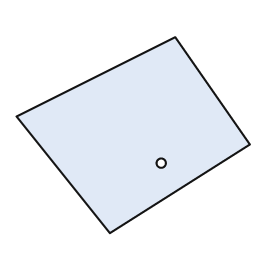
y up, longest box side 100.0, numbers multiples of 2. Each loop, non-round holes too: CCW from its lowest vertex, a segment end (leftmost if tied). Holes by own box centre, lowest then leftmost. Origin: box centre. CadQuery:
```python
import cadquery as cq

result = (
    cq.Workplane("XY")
    .moveTo(-10.0, -42.0)
    .lineTo(50.0, -4.0)
    .lineTo(18.0, 42.0)
    .lineTo(-50.0, 8.0)
    .close()
    .moveTo(12.0, -12.0)
    .circle(2.0)
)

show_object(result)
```